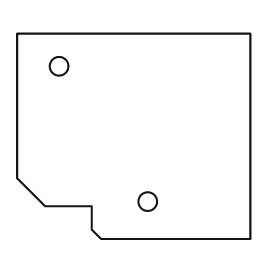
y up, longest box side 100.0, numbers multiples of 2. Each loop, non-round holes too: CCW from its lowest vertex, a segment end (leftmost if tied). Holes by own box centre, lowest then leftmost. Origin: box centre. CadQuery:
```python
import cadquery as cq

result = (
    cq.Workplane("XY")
    .moveTo(-14.0, -44.0)
    .lineTo(50.0, -44.0)
    .lineTo(50.0, 44.0)
    .lineTo(-50.0, 44.0)
    .lineTo(-50.0, -18.0)
    .lineTo(-38.0, -30.0)
    .lineTo(-18.0, -30.0)
    .lineTo(-18.0, -40.0)
    .close()
    .moveTo(6.0, -28.0)
    .circle(4.0)
    .moveTo(-32.0, 30.0)
    .circle(4.0)
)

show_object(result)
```